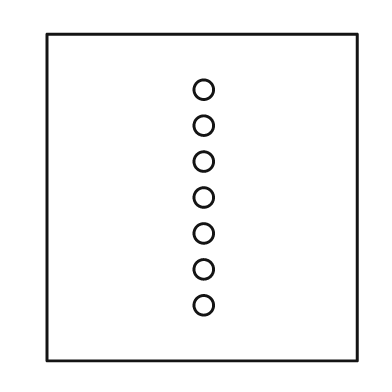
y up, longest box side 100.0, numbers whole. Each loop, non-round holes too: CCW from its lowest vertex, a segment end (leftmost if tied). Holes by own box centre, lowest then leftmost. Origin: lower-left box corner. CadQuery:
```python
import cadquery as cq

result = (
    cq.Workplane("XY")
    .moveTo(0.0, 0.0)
    .lineTo(95.0, 0.0)
    .lineTo(95.0, 100.0)
    .lineTo(0.0, 100.0)
    .close()
    .moveTo(48.0, 17.0)
    .circle(3.0)
    .moveTo(48.0, 28.0)
    .circle(3.0)
    .moveTo(48.0, 39.0)
    .circle(3.0)
    .moveTo(48.0, 50.0)
    .circle(3.0)
    .moveTo(48.0, 61.0)
    .circle(3.0)
    .moveTo(48.0, 72.0)
    .circle(3.0)
    .moveTo(48.0, 83.0)
    .circle(3.0)
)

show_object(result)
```